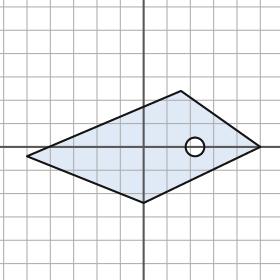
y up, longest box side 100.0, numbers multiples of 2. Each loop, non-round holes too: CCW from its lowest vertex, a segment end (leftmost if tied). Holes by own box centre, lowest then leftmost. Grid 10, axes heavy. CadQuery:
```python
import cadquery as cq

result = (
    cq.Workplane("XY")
    .moveTo(0.0, -24.0)
    .lineTo(50.0, 0.0)
    .lineTo(16.0, 24.0)
    .lineTo(-50.0, -4.0)
    .close()
    .moveTo(22.0, 0.0)
    .circle(4.0)
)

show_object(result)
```